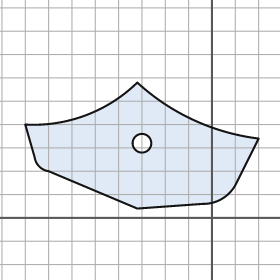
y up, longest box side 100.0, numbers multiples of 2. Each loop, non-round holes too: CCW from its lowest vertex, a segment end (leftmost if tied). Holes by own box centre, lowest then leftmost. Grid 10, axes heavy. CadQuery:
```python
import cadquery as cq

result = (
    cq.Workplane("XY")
    .moveTo(-32.0, 4.0)
    .lineTo(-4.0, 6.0)
    .threePointArc((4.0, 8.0), (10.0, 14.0))
    .lineTo(20.0, 34.0)
    .threePointArc((-8.0, 42.0), (-32.0, 58.0))
    .threePointArc((-54.0, 44.0), (-80.0, 40.0))
    .lineTo(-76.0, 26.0)
    .threePointArc((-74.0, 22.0), (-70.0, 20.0))
    .close()
    .moveTo(-30.0, 32.0)
    .circle(4.0)
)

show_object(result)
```